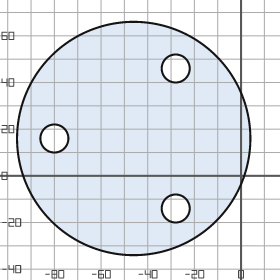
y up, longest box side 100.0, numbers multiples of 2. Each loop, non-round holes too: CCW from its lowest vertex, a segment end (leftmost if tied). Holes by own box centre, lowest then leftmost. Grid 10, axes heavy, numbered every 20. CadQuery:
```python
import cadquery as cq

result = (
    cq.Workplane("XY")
    .moveTo(-46.0, 16.0)
    .circle(50.0)
    .moveTo(-28.0, -14.0)
    .circle(6.0)
    .moveTo(-80.0, 16.0)
    .circle(6.0)
    .moveTo(-28.0, 46.0)
    .circle(6.0)
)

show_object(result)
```